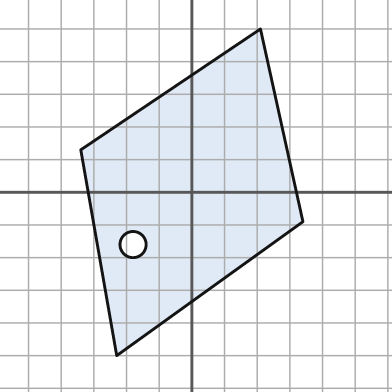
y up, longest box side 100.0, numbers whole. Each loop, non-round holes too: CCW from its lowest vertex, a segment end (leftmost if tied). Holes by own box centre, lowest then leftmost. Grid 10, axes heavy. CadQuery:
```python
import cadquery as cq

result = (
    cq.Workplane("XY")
    .moveTo(-23.0, -50.0)
    .lineTo(34.0, -9.0)
    .lineTo(21.0, 50.0)
    .lineTo(-34.0, 13.0)
    .close()
    .moveTo(-18.0, -16.0)
    .circle(4.0)
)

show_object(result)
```